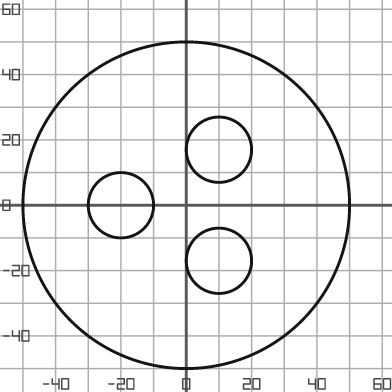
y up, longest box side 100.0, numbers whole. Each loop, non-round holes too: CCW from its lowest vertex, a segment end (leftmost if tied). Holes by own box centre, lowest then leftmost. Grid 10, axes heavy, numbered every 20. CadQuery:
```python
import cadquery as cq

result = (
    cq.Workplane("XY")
    .moveTo(0.0, 0.0)
    .circle(50.0)
    .moveTo(10.0, -17.0)
    .circle(10.0)
    .moveTo(-20.0, 0.0)
    .circle(10.0)
    .moveTo(10.0, 17.0)
    .circle(10.0)
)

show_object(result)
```